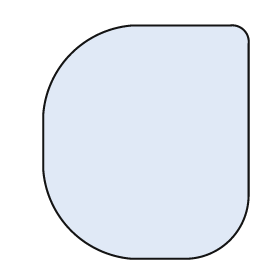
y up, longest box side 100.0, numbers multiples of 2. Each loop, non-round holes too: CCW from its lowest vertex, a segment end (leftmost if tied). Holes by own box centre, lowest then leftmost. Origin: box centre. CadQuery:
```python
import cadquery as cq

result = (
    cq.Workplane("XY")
    .moveTo(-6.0, -50.0)
    .lineTo(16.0, -50.0)
    .threePointArc((36.0, -42.0), (44.0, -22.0))
    .lineTo(44.0, 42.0)
    .threePointArc((42.0, 48.0), (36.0, 50.0))
    .lineTo(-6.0, 50.0)
    .threePointArc((-32.0, 38.0), (-44.0, 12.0))
    .lineTo(-44.0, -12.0)
    .threePointArc((-32.0, -38.0), (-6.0, -50.0))
    .close()
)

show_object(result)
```